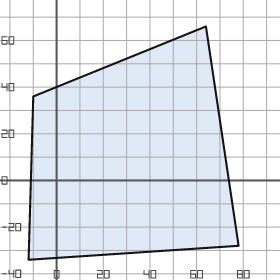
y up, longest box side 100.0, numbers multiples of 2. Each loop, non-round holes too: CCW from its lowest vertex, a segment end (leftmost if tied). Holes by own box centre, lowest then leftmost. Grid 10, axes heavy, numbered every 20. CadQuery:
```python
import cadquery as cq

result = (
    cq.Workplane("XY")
    .moveTo(-12.0, -34.0)
    .lineTo(78.0, -28.0)
    .lineTo(64.0, 66.0)
    .lineTo(-10.0, 36.0)
    .close()
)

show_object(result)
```